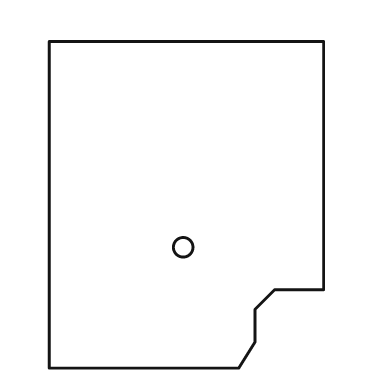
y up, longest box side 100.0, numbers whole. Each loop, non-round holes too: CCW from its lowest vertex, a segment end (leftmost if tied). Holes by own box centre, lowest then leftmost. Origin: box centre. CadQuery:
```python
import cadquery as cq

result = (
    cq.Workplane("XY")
    .moveTo(-42.0, -50.0)
    .lineTo(16.0, -50.0)
    .lineTo(21.0, -42.0)
    .lineTo(21.0, -32.0)
    .lineTo(27.0, -26.0)
    .lineTo(42.0, -26.0)
    .lineTo(42.0, 50.0)
    .lineTo(-42.0, 50.0)
    .close()
    .moveTo(-1.0, -13.0)
    .circle(3.0)
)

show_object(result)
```